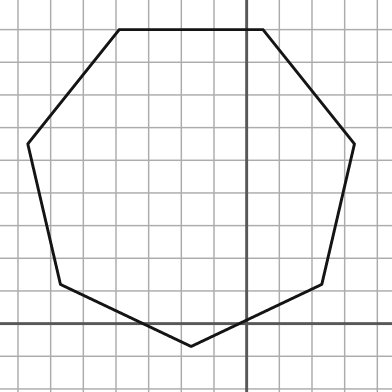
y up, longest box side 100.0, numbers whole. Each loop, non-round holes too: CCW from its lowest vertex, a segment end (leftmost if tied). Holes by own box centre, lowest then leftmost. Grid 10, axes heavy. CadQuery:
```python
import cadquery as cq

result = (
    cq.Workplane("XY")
    .moveTo(-17.0, -7.0)
    .lineTo(23.0, 12.0)
    .lineTo(33.0, 55.0)
    .lineTo(5.0, 90.0)
    .lineTo(-39.0, 90.0)
    .lineTo(-67.0, 55.0)
    .lineTo(-57.0, 12.0)
    .close()
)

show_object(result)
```